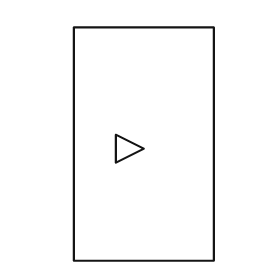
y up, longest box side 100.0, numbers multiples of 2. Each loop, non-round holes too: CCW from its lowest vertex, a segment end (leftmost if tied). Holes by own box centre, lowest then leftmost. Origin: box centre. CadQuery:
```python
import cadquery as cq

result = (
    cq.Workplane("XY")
    .moveTo(-30.0, -50.0)
    .lineTo(30.0, -50.0)
    .lineTo(30.0, 50.0)
    .lineTo(-30.0, 50.0)
    .close()
    .moveTo(-12.0, -8.0)
    .lineTo(0.0, -2.0)
    .lineTo(-12.0, 4.0)
    .close()
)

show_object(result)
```